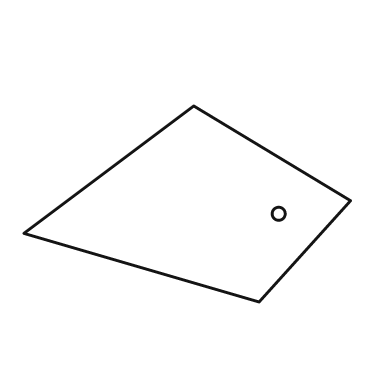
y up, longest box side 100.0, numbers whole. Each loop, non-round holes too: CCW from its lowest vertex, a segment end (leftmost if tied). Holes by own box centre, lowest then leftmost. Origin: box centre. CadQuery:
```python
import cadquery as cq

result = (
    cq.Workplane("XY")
    .moveTo(22.0, -30.0)
    .lineTo(50.0, 1.0)
    .lineTo(2.0, 30.0)
    .lineTo(-50.0, -9.0)
    .close()
    .moveTo(28.0, -3.0)
    .circle(2.0)
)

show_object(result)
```